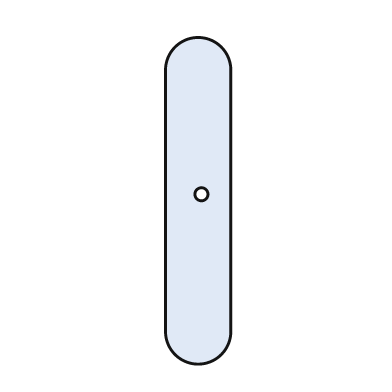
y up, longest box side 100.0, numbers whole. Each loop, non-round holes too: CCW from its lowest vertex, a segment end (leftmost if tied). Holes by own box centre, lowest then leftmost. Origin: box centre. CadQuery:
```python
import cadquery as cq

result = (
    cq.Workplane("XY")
    .moveTo(-10.0, -40.0)
    .threePointArc((0.0, -50.0), (10.0, -40.0))
    .lineTo(10.0, 40.0)
    .threePointArc((0.0, 50.0), (-10.0, 40.0))
    .close()
    .moveTo(1.0, 2.0)
    .circle(2.0)
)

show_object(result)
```